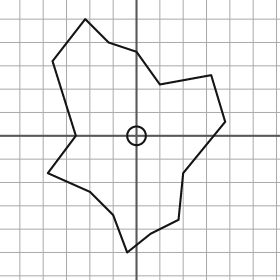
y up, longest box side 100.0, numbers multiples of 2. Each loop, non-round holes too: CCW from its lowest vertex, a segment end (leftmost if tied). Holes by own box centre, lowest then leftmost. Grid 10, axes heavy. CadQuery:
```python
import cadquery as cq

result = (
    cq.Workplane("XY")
    .moveTo(-4.0, -50.0)
    .lineTo(6.0, -42.0)
    .lineTo(18.0, -36.0)
    .lineTo(20.0, -16.0)
    .lineTo(38.0, 6.0)
    .lineTo(32.0, 26.0)
    .lineTo(10.0, 22.0)
    .lineTo(0.0, 36.0)
    .lineTo(-12.0, 40.0)
    .lineTo(-22.0, 50.0)
    .lineTo(-36.0, 32.0)
    .lineTo(-26.0, 0.0)
    .lineTo(-38.0, -16.0)
    .lineTo(-20.0, -24.0)
    .lineTo(-10.0, -34.0)
    .close()
    .moveTo(0.0, 0.0)
    .circle(4.0)
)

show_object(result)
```